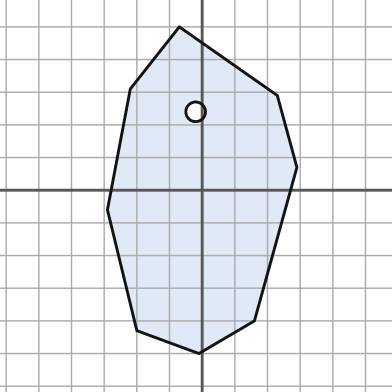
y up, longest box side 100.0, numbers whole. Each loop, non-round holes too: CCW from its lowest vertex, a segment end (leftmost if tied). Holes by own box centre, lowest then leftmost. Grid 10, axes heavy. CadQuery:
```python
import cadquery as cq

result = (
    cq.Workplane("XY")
    .moveTo(-1.0, -50.0)
    .lineTo(16.0, -40.0)
    .lineTo(29.0, 7.0)
    .lineTo(23.0, 29.0)
    .lineTo(-7.0, 50.0)
    .lineTo(-22.0, 31.0)
    .lineTo(-29.0, -6.0)
    .lineTo(-20.0, -43.0)
    .close()
    .moveTo(-2.0, 24.0)
    .circle(3.0)
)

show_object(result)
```